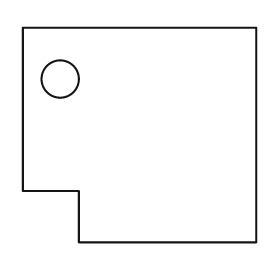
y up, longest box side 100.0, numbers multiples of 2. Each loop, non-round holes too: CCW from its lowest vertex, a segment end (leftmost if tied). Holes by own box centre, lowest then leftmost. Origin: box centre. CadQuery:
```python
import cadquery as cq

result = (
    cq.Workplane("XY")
    .moveTo(-26.0, -46.0)
    .lineTo(50.0, -46.0)
    .lineTo(50.0, 46.0)
    .lineTo(-50.0, 46.0)
    .lineTo(-50.0, -24.0)
    .lineTo(-26.0, -24.0)
    .close()
    .moveTo(-34.0, 24.0)
    .circle(8.0)
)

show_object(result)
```